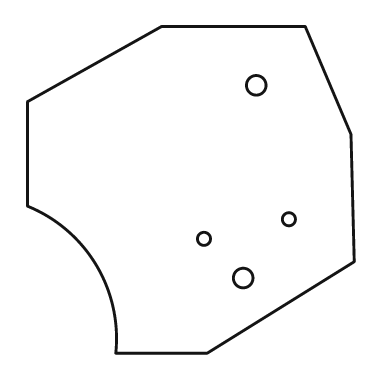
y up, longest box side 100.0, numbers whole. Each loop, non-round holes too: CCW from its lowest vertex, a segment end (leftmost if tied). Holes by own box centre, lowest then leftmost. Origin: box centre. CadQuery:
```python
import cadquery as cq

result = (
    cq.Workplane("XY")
    .moveTo(-23.0, -50.0)
    .lineTo(5.0, -50.0)
    .lineTo(50.0, -22.0)
    .lineTo(49.0, 17.0)
    .lineTo(35.0, 50.0)
    .lineTo(-9.0, 50.0)
    .lineTo(-50.0, 27.0)
    .lineTo(-50.0, -5.0)
    .threePointArc((-29.0, -23.0), (-23.0, -50.0))
    .close()
    .moveTo(16.0, -27.0)
    .circle(3.0)
    .moveTo(4.0, -15.0)
    .circle(2.0)
    .moveTo(30.0, -9.0)
    .circle(2.0)
    .moveTo(20.0, 32.0)
    .circle(3.0)
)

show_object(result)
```